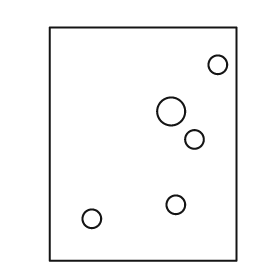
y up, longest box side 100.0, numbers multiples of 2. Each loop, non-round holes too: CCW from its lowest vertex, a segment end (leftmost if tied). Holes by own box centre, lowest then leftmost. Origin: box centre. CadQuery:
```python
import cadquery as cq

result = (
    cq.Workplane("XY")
    .moveTo(-40.0, -50.0)
    .lineTo(40.0, -50.0)
    .lineTo(40.0, 50.0)
    .lineTo(-40.0, 50.0)
    .close()
    .moveTo(-22.0, -32.0)
    .circle(4.0)
    .moveTo(14.0, -26.0)
    .circle(4.0)
    .moveTo(22.0, 2.0)
    .circle(4.0)
    .moveTo(12.0, 14.0)
    .circle(6.0)
    .moveTo(32.0, 34.0)
    .circle(4.0)
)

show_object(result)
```